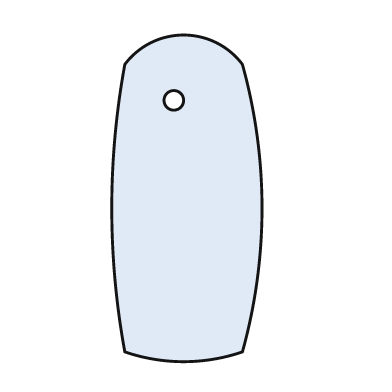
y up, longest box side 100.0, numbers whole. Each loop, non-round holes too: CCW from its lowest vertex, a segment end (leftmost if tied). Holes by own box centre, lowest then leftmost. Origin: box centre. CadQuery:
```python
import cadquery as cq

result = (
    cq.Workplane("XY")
    .moveTo(-19.0, -47.0)
    .threePointArc((-1.0, -50.0), (17.0, -47.0))
    .threePointArc((23.0, -3.0), (17.0, 41.0))
    .threePointArc((-1.0, 50.0), (-19.0, 41.0))
    .threePointArc((-23.0, -3.0), (-19.0, -47.0))
    .close()
    .moveTo(-4.0, 30.0)
    .circle(3.0)
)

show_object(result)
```